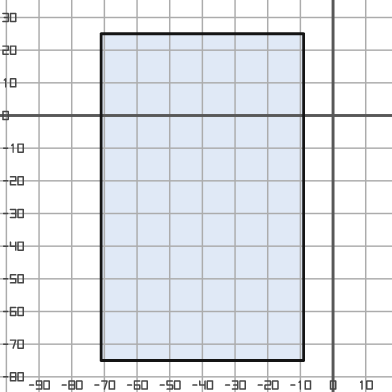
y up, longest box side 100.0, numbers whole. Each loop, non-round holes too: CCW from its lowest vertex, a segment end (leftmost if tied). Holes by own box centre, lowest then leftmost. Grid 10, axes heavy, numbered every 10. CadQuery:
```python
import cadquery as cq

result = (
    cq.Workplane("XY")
    .moveTo(-71.0, -75.0)
    .lineTo(-9.0, -75.0)
    .lineTo(-9.0, 25.0)
    .lineTo(-71.0, 25.0)
    .close()
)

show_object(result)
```